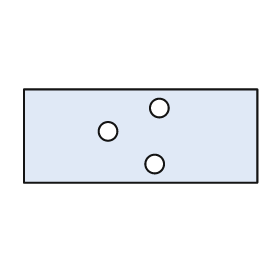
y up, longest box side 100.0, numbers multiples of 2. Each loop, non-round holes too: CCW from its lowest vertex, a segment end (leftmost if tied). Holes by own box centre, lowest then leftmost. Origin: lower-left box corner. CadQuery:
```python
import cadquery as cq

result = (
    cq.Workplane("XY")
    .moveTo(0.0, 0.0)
    .lineTo(100.0, 0.0)
    .lineTo(100.0, 40.0)
    .lineTo(0.0, 40.0)
    .close()
    .moveTo(56.0, 8.0)
    .circle(4.0)
    .moveTo(36.0, 22.0)
    .circle(4.0)
    .moveTo(58.0, 32.0)
    .circle(4.0)
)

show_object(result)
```